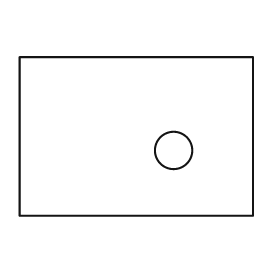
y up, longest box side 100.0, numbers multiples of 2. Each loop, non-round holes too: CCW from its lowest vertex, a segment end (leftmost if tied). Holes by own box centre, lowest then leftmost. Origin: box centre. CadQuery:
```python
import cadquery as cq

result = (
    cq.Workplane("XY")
    .moveTo(-50.0, -34.0)
    .lineTo(50.0, -34.0)
    .lineTo(50.0, 34.0)
    .lineTo(-50.0, 34.0)
    .close()
    .moveTo(16.0, -6.0)
    .circle(8.0)
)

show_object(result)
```